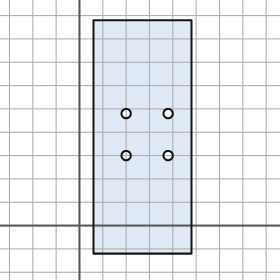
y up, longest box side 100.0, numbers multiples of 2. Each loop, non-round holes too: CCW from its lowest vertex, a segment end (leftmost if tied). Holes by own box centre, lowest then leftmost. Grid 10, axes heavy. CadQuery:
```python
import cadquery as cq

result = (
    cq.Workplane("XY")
    .moveTo(6.0, -12.0)
    .lineTo(48.0, -12.0)
    .lineTo(48.0, 88.0)
    .lineTo(6.0, 88.0)
    .close()
    .moveTo(20.0, 30.0)
    .circle(2.0)
    .moveTo(38.0, 30.0)
    .circle(2.0)
    .moveTo(20.0, 48.0)
    .circle(2.0)
    .moveTo(38.0, 48.0)
    .circle(2.0)
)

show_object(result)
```